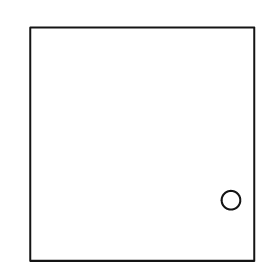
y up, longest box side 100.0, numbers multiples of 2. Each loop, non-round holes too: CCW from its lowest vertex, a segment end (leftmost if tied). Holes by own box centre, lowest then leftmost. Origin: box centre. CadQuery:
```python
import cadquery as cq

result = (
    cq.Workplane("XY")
    .moveTo(-48.0, -50.0)
    .lineTo(48.0, -50.0)
    .lineTo(48.0, 50.0)
    .lineTo(-48.0, 50.0)
    .close()
    .moveTo(38.0, -24.0)
    .circle(4.0)
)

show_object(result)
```